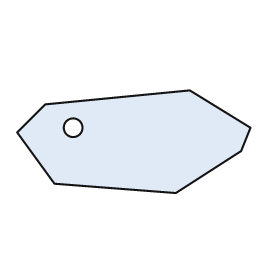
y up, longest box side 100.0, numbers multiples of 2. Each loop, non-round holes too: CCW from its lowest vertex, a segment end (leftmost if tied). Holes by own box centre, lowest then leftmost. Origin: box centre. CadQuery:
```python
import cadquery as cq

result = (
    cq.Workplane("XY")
    .moveTo(18.0, -22.0)
    .lineTo(46.0, -4.0)
    .lineTo(50.0, 6.0)
    .lineTo(24.0, 22.0)
    .lineTo(-38.0, 16.0)
    .lineTo(-50.0, 4.0)
    .lineTo(-34.0, -18.0)
    .close()
    .moveTo(-26.0, 6.0)
    .circle(4.0)
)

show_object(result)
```